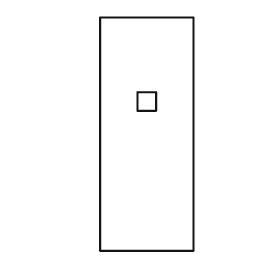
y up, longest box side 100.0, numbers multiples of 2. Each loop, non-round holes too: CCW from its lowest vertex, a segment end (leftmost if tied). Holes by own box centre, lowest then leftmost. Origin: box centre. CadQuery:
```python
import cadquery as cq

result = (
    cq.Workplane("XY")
    .moveTo(-20.0, -50.0)
    .lineTo(20.0, -50.0)
    .lineTo(20.0, 50.0)
    .lineTo(-20.0, 50.0)
    .close()
    .moveTo(-4.0, 10.0)
    .lineTo(4.0, 10.0)
    .lineTo(4.0, 18.0)
    .lineTo(-4.0, 18.0)
    .close()
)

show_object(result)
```